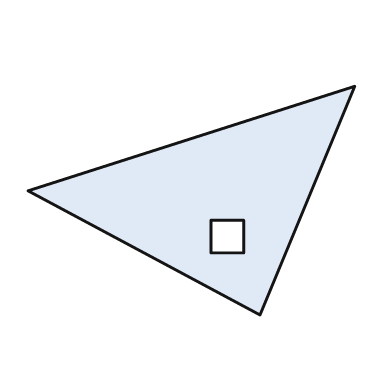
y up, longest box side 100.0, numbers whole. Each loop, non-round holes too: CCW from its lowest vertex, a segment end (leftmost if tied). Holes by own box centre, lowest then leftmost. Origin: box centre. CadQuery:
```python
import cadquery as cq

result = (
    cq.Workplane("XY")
    .moveTo(21.0, -35.0)
    .lineTo(50.0, 35.0)
    .lineTo(-50.0, 3.0)
    .close()
    .moveTo(6.0, -16.0)
    .lineTo(16.0, -16.0)
    .lineTo(16.0, -6.0)
    .lineTo(6.0, -6.0)
    .close()
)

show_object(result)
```